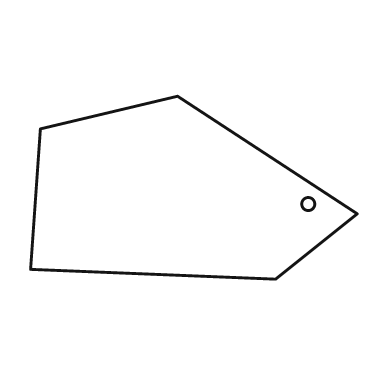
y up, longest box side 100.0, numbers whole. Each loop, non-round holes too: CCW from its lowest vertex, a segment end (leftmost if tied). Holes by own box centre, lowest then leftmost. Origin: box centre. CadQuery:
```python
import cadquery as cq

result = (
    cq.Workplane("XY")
    .moveTo(25.0, -28.0)
    .lineTo(50.0, -8.0)
    .lineTo(-5.0, 28.0)
    .lineTo(-47.0, 18.0)
    .lineTo(-50.0, -25.0)
    .close()
    .moveTo(35.0, -5.0)
    .circle(2.0)
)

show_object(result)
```